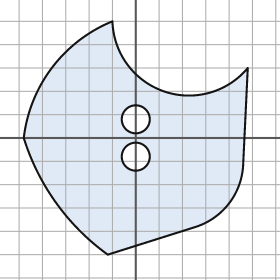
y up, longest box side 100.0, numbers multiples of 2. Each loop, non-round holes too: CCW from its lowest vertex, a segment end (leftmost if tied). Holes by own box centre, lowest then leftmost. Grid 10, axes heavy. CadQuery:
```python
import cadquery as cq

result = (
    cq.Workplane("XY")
    .moveTo(-12.0, -50.0)
    .lineTo(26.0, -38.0)
    .threePointArc((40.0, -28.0), (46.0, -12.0))
    .lineTo(48.0, 30.0)
    .threePointArc((12.0, 20.0), (-10.0, 50.0))
    .threePointArc((-36.0, 30.0), (-48.0, 0.0))
    .threePointArc((-34.0, -28.0), (-12.0, -50.0))
    .close()
    .moveTo(0.0, -8.0)
    .circle(6.0)
    .moveTo(0.0, 8.0)
    .circle(6.0)
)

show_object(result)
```